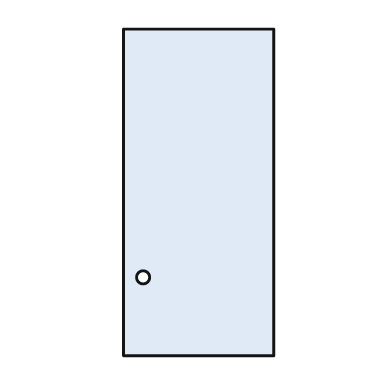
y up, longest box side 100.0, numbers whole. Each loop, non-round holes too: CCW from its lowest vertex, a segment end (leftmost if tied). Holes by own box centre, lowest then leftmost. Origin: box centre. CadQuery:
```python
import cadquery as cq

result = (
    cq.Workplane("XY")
    .moveTo(-23.0, -50.0)
    .lineTo(23.0, -50.0)
    .lineTo(23.0, 50.0)
    .lineTo(-23.0, 50.0)
    .close()
    .moveTo(-17.0, -26.0)
    .circle(2.0)
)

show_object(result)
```